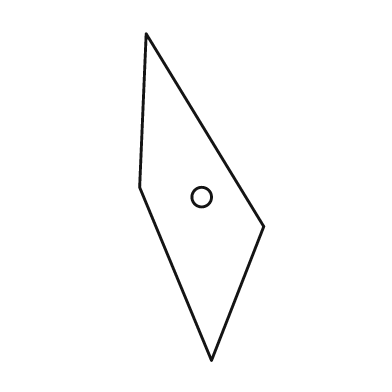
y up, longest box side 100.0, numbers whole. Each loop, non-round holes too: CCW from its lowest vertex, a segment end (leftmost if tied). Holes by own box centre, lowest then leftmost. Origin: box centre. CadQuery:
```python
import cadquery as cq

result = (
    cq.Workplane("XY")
    .moveTo(3.0, -50.0)
    .lineTo(19.0, -9.0)
    .lineTo(-17.0, 50.0)
    .lineTo(-19.0, 3.0)
    .close()
    .moveTo(0.0, 0.0)
    .circle(3.0)
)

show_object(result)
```